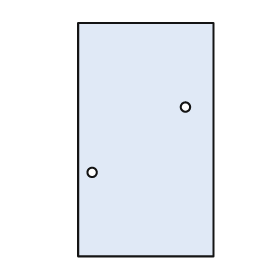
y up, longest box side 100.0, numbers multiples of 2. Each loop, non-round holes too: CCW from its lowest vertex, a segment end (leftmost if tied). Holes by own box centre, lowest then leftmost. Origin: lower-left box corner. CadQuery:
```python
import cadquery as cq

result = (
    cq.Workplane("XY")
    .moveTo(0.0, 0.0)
    .lineTo(58.0, 0.0)
    .lineTo(58.0, 100.0)
    .lineTo(0.0, 100.0)
    .close()
    .moveTo(6.0, 36.0)
    .circle(2.0)
    .moveTo(46.0, 64.0)
    .circle(2.0)
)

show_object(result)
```